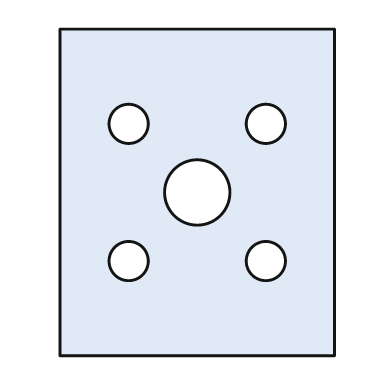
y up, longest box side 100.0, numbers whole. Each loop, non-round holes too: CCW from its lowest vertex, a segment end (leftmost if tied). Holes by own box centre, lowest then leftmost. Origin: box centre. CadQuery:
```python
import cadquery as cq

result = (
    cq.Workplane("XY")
    .moveTo(-42.0, -50.0)
    .lineTo(42.0, -50.0)
    .lineTo(42.0, 50.0)
    .lineTo(-42.0, 50.0)
    .close()
    .moveTo(-21.0, -21.0)
    .circle(6.0)
    .moveTo(21.0, -21.0)
    .circle(6.0)
    .moveTo(0.0, 0.0)
    .circle(10.0)
    .moveTo(-21.0, 21.0)
    .circle(6.0)
    .moveTo(21.0, 21.0)
    .circle(6.0)
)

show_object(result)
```